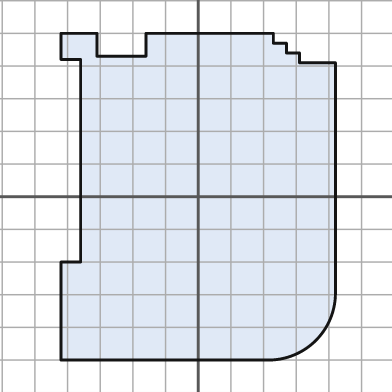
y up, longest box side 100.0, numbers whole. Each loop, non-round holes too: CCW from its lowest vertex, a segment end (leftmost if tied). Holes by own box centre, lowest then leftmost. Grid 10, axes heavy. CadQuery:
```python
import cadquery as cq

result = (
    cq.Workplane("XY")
    .moveTo(-42.0, -50.0)
    .lineTo(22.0, -50.0)
    .threePointArc((36.0, -44.0), (42.0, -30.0))
    .lineTo(42.0, 41.0)
    .lineTo(31.0, 41.0)
    .lineTo(31.0, 44.0)
    .lineTo(27.0, 44.0)
    .lineTo(27.0, 47.0)
    .lineTo(23.0, 47.0)
    .lineTo(23.0, 50.0)
    .lineTo(-16.0, 50.0)
    .lineTo(-16.0, 43.0)
    .lineTo(-31.0, 43.0)
    .lineTo(-31.0, 50.0)
    .lineTo(-42.0, 50.0)
    .lineTo(-42.0, 42.0)
    .lineTo(-36.0, 42.0)
    .lineTo(-36.0, -20.0)
    .lineTo(-42.0, -20.0)
    .close()
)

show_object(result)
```